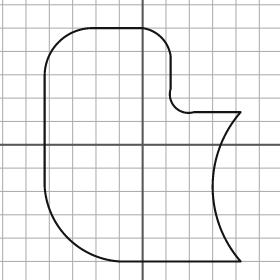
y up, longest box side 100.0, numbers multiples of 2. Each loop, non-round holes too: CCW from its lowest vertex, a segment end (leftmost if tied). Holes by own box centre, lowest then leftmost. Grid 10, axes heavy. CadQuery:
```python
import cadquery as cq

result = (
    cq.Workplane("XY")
    .moveTo(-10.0, -50.0)
    .lineTo(42.0, -50.0)
    .threePointArc((30.0, -18.0), (42.0, 14.0))
    .lineTo(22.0, 14.0)
    .threePointArc((14.0, 16.0), (12.0, 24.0))
    .lineTo(12.0, 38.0)
    .threePointArc((8.0, 46.0), (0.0, 50.0))
    .lineTo(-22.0, 50.0)
    .threePointArc((-36.0, 44.0), (-42.0, 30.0))
    .lineTo(-42.0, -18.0)
    .threePointArc((-32.0, -40.0), (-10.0, -50.0))
    .close()
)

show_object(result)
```